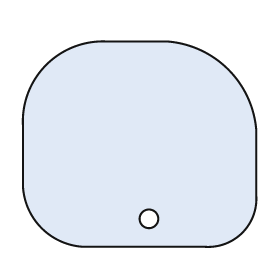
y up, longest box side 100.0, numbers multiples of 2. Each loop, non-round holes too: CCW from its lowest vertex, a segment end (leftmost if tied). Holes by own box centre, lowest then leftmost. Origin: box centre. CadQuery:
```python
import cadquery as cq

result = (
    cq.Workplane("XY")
    .moveTo(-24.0, -44.0)
    .lineTo(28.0, -44.0)
    .threePointArc((44.0, -38.0), (50.0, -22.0))
    .lineTo(50.0, 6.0)
    .threePointArc((38.0, 32.0), (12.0, 44.0))
    .lineTo(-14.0, 44.0)
    .threePointArc((-40.0, 34.0), (-50.0, 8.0))
    .lineTo(-50.0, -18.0)
    .threePointArc((-42.0, -36.0), (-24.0, -44.0))
    .close()
    .moveTo(4.0, -32.0)
    .circle(4.0)
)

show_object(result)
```